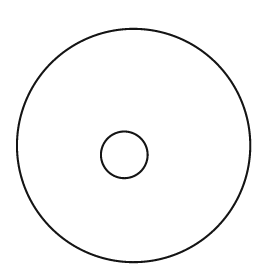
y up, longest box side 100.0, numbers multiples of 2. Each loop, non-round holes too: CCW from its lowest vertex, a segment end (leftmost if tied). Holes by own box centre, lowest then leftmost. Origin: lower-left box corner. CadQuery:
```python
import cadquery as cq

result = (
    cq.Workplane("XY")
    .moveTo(50.0, 50.0)
    .circle(50.0)
    .moveTo(46.0, 46.0)
    .circle(10.0)
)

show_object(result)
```